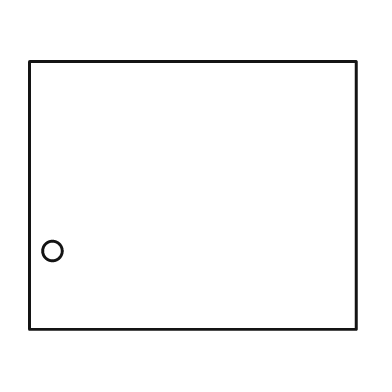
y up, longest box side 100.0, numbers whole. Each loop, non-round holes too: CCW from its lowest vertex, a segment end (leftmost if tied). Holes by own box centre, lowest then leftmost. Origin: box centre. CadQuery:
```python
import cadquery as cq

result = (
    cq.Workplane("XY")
    .moveTo(-50.0, -41.0)
    .lineTo(50.0, -41.0)
    .lineTo(50.0, 41.0)
    .lineTo(-50.0, 41.0)
    .close()
    .moveTo(-43.0, -17.0)
    .circle(3.0)
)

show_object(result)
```